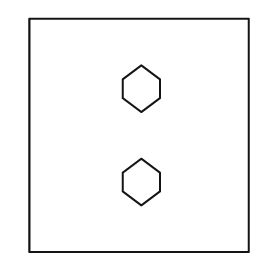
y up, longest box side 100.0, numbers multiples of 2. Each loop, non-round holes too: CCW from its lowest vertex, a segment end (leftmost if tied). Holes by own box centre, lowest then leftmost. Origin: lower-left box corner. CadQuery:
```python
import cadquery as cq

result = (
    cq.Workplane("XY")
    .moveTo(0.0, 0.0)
    .lineTo(94.0, 0.0)
    .lineTo(94.0, 100.0)
    .lineTo(0.0, 100.0)
    .close()
    .moveTo(48.0, 20.0)
    .lineTo(56.0, 26.0)
    .lineTo(56.0, 34.0)
    .lineTo(48.0, 40.0)
    .lineTo(40.0, 34.0)
    .lineTo(40.0, 26.0)
    .close()
    .moveTo(48.0, 60.0)
    .lineTo(56.0, 66.0)
    .lineTo(56.0, 74.0)
    .lineTo(48.0, 80.0)
    .lineTo(40.0, 74.0)
    .lineTo(40.0, 66.0)
    .close()
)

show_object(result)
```